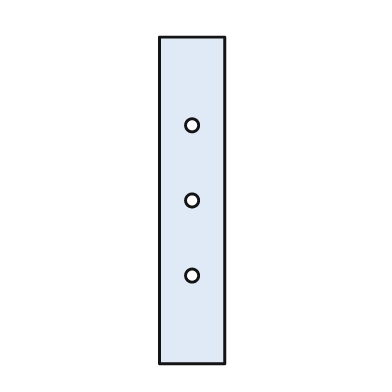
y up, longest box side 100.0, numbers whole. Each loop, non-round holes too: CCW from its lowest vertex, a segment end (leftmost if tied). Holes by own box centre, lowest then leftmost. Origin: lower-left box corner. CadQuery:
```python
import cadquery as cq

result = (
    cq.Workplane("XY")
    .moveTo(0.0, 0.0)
    .lineTo(20.0, 0.0)
    .lineTo(20.0, 100.0)
    .lineTo(0.0, 100.0)
    .close()
    .moveTo(10.0, 27.0)
    .circle(2.0)
    .moveTo(10.0, 50.0)
    .circle(2.0)
    .moveTo(10.0, 73.0)
    .circle(2.0)
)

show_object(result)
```